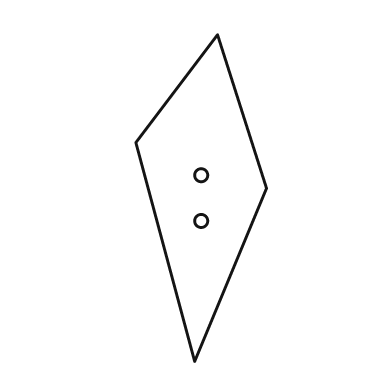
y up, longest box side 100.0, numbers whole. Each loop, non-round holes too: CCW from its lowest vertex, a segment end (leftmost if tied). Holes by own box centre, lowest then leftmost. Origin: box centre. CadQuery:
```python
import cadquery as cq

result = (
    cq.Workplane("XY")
    .moveTo(-2.0, -50.0)
    .lineTo(20.0, 3.0)
    .lineTo(5.0, 50.0)
    .lineTo(-20.0, 17.0)
    .close()
    .moveTo(0.0, -7.0)
    .circle(2.0)
    .moveTo(0.0, 7.0)
    .circle(2.0)
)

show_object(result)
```